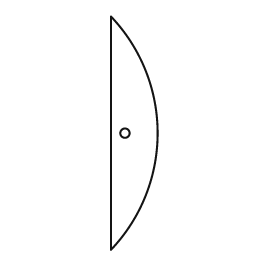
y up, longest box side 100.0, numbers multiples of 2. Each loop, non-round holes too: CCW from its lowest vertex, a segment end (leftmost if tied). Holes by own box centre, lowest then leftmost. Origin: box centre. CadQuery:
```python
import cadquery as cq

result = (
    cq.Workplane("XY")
    .moveTo(-10.0, -50.0)
    .threePointArc((10.0, 0.0), (-10.0, 50.0))
    .close()
    .moveTo(-4.0, 0.0)
    .circle(2.0)
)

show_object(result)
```